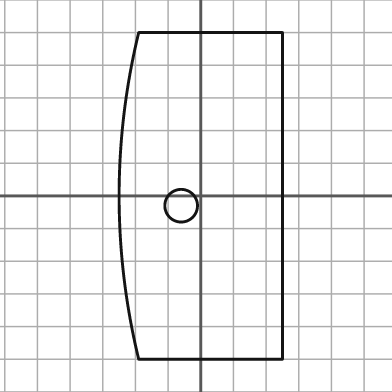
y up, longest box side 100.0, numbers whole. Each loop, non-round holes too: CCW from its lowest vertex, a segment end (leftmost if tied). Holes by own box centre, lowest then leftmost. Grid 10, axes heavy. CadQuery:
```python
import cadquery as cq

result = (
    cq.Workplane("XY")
    .moveTo(-19.0, -50.0)
    .lineTo(25.0, -50.0)
    .lineTo(25.0, 50.0)
    .lineTo(-19.0, 50.0)
    .threePointArc((-25.0, 0.0), (-19.0, -50.0))
    .close()
    .moveTo(-6.0, -3.0)
    .circle(5.0)
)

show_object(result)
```